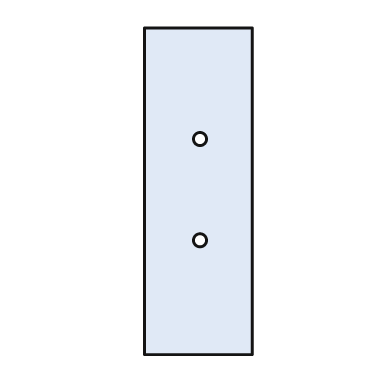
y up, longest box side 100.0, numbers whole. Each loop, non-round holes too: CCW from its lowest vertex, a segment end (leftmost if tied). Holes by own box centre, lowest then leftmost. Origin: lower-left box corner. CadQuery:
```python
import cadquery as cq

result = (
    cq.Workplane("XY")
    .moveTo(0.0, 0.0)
    .lineTo(33.0, 0.0)
    .lineTo(33.0, 100.0)
    .lineTo(0.0, 100.0)
    .close()
    .moveTo(17.0, 35.0)
    .circle(2.0)
    .moveTo(17.0, 66.0)
    .circle(2.0)
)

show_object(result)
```